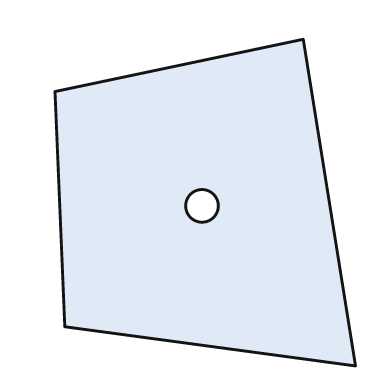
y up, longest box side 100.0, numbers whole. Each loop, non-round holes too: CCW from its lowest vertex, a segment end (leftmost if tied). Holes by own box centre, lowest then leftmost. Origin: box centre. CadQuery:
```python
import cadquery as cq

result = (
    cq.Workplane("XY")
    .moveTo(46.0, -50.0)
    .lineTo(30.0, 50.0)
    .lineTo(-46.0, 34.0)
    .lineTo(-43.0, -38.0)
    .close()
    .moveTo(-1.0, -1.0)
    .circle(5.0)
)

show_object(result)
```